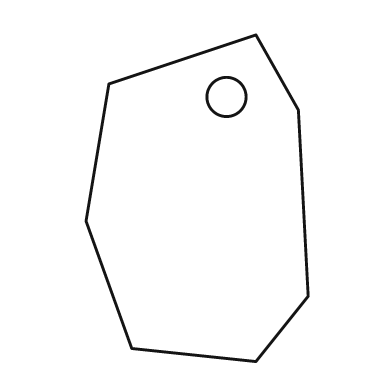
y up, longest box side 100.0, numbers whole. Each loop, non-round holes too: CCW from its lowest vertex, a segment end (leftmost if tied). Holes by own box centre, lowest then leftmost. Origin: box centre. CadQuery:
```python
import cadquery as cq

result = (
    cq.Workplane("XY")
    .moveTo(18.0, -50.0)
    .lineTo(34.0, -30.0)
    .lineTo(31.0, 27.0)
    .lineTo(18.0, 50.0)
    .lineTo(-27.0, 35.0)
    .lineTo(-34.0, -7.0)
    .lineTo(-20.0, -46.0)
    .close()
    .moveTo(9.0, 31.0)
    .circle(6.0)
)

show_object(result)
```